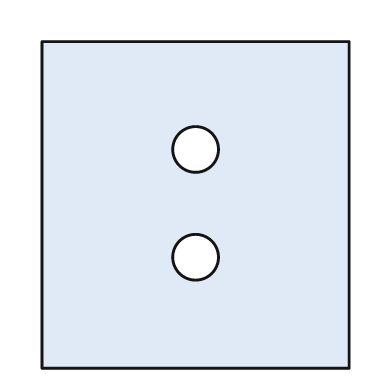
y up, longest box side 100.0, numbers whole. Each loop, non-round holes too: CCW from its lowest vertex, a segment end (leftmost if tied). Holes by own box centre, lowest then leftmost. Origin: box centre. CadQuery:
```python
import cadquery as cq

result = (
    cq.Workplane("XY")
    .moveTo(-47.0, -50.0)
    .lineTo(47.0, -50.0)
    .lineTo(47.0, 50.0)
    .lineTo(-47.0, 50.0)
    .close()
    .moveTo(0.0, -16.0)
    .circle(7.0)
    .moveTo(0.0, 17.0)
    .circle(7.0)
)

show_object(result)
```